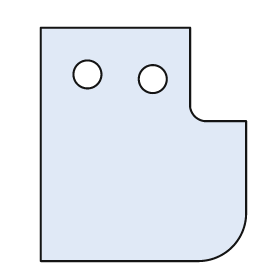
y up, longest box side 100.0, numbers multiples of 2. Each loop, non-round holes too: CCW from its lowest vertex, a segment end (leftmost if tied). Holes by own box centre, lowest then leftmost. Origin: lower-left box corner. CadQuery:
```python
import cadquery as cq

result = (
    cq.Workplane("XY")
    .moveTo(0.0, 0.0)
    .lineTo(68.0, 0.0)
    .threePointArc((82.0, 6.0), (88.0, 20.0))
    .lineTo(88.0, 60.0)
    .lineTo(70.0, 60.0)
    .threePointArc((66.0, 62.0), (64.0, 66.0))
    .lineTo(64.0, 100.0)
    .lineTo(0.0, 100.0)
    .close()
    .moveTo(48.0, 78.0)
    .circle(6.0)
    .moveTo(20.0, 80.0)
    .circle(6.0)
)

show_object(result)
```